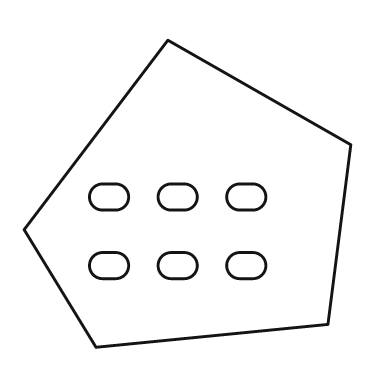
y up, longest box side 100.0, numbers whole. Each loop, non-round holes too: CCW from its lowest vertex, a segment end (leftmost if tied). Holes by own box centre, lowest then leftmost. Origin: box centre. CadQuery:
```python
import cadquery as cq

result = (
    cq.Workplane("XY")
    .moveTo(-28.0, -47.0)
    .lineTo(43.0, -40.0)
    .lineTo(50.0, 15.0)
    .lineTo(-6.0, 47.0)
    .lineTo(-50.0, -11.0)
    .close()
    .moveTo(-26.0, -26.0)
    .lineTo(-22.0, -26.0)
    .threePointArc((-18.0, -22.0), (-22.0, -18.0))
    .lineTo(-26.0, -18.0)
    .threePointArc((-30.0, -22.0), (-26.0, -26.0))
    .close()
    .moveTo(-5.0, -26.0)
    .lineTo(-1.0, -26.0)
    .threePointArc((3.0, -22.0), (-1.0, -18.0))
    .lineTo(-5.0, -18.0)
    .threePointArc((-9.0, -22.0), (-5.0, -26.0))
    .close()
    .moveTo(16.0, -26.0)
    .lineTo(20.0, -26.0)
    .threePointArc((24.0, -22.0), (20.0, -18.0))
    .lineTo(16.0, -18.0)
    .threePointArc((12.0, -22.0), (16.0, -26.0))
    .close()
    .moveTo(-26.0, -5.0)
    .lineTo(-22.0, -5.0)
    .threePointArc((-18.0, -1.0), (-22.0, 3.0))
    .lineTo(-26.0, 3.0)
    .threePointArc((-30.0, -1.0), (-26.0, -5.0))
    .close()
    .moveTo(-5.0, -5.0)
    .lineTo(-1.0, -5.0)
    .threePointArc((3.0, -1.0), (-1.0, 3.0))
    .lineTo(-5.0, 3.0)
    .threePointArc((-9.0, -1.0), (-5.0, -5.0))
    .close()
    .moveTo(16.0, -5.0)
    .lineTo(20.0, -5.0)
    .threePointArc((24.0, -1.0), (20.0, 3.0))
    .lineTo(16.0, 3.0)
    .threePointArc((12.0, -1.0), (16.0, -5.0))
    .close()
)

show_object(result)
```